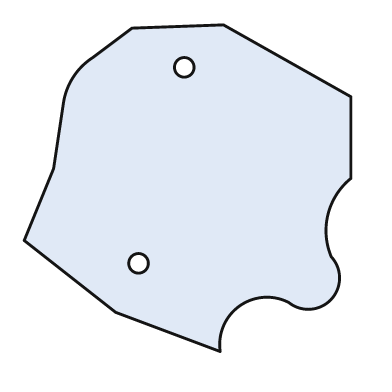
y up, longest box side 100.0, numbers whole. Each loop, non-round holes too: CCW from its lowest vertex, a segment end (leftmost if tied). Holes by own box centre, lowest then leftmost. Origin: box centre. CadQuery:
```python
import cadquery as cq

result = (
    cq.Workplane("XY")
    .moveTo(10.0, -50.0)
    .threePointArc((16.0, -36.0), (31.0, -35.0))
    .threePointArc((44.0, -34.0), (44.0, -21.0))
    .threePointArc((43.0, -8.0), (50.0, 3.0))
    .lineTo(50.0, 28.0)
    .lineTo(11.0, 50.0)
    .lineTo(-17.0, 49.0)
    .lineTo(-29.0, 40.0)
    .threePointArc((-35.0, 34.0), (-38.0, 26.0))
    .lineTo(-41.0, 6.0)
    .lineTo(-50.0, -16.0)
    .lineTo(-22.0, -38.0)
    .close()
    .moveTo(-15.0, -23.0)
    .circle(3.0)
    .moveTo(-1.0, 37.0)
    .circle(3.0)
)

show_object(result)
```